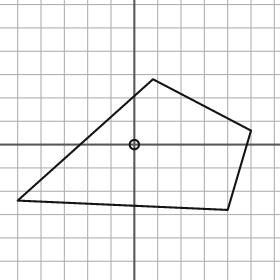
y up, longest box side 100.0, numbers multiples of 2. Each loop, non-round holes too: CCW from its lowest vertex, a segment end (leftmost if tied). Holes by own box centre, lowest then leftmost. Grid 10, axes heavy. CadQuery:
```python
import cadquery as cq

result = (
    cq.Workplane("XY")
    .moveTo(40.0, -28.0)
    .lineTo(50.0, 6.0)
    .lineTo(8.0, 28.0)
    .lineTo(-50.0, -24.0)
    .close()
    .moveTo(0.0, 0.0)
    .circle(2.0)
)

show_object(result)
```